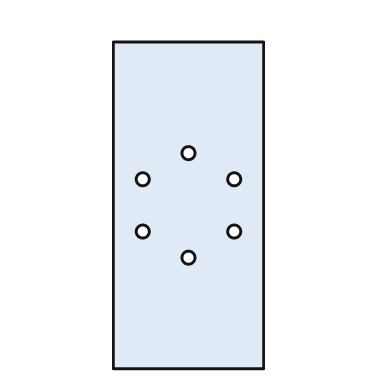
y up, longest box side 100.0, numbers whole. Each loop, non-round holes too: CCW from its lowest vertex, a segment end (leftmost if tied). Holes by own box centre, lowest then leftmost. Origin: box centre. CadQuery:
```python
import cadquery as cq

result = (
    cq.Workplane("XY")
    .moveTo(-23.0, -50.0)
    .lineTo(23.0, -50.0)
    .lineTo(23.0, 50.0)
    .lineTo(-23.0, 50.0)
    .close()
    .moveTo(0.0, -16.0)
    .circle(2.0)
    .moveTo(-14.0, -8.0)
    .circle(2.0)
    .moveTo(14.0, -8.0)
    .circle(2.0)
    .moveTo(-14.0, 8.0)
    .circle(2.0)
    .moveTo(14.0, 8.0)
    .circle(2.0)
    .moveTo(0.0, 16.0)
    .circle(2.0)
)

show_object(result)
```